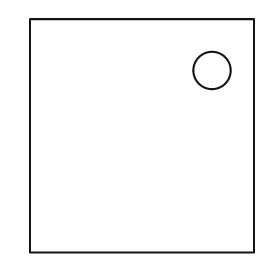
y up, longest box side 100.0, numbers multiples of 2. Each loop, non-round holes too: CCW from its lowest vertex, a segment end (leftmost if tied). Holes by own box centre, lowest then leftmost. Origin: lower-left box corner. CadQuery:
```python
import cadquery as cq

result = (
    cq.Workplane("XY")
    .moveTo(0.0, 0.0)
    .lineTo(96.0, 0.0)
    .lineTo(96.0, 100.0)
    .lineTo(0.0, 100.0)
    .close()
    .moveTo(78.0, 78.0)
    .circle(8.0)
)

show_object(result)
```